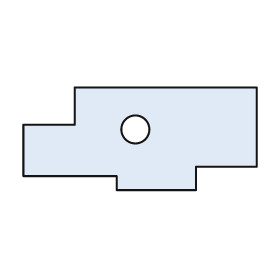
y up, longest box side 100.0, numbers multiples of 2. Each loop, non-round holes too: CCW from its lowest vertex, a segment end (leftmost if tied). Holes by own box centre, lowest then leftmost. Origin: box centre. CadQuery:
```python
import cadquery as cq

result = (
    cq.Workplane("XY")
    .moveTo(-10.0, -22.0)
    .lineTo(24.0, -22.0)
    .lineTo(24.0, -12.0)
    .lineTo(50.0, -12.0)
    .lineTo(50.0, 22.0)
    .lineTo(-28.0, 22.0)
    .lineTo(-28.0, 6.0)
    .lineTo(-50.0, 6.0)
    .lineTo(-50.0, -16.0)
    .lineTo(-10.0, -16.0)
    .close()
    .moveTo(-2.0, 4.0)
    .circle(6.0)
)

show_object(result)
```